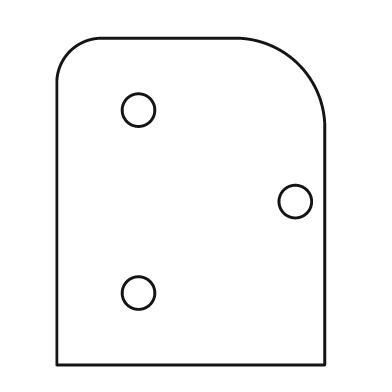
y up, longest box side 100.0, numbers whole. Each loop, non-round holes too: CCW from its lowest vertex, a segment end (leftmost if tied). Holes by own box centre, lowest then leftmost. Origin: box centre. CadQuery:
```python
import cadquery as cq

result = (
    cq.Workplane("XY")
    .moveTo(-41.0, -50.0)
    .lineTo(41.0, -50.0)
    .lineTo(41.0, 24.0)
    .threePointArc((33.0, 42.0), (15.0, 50.0))
    .lineTo(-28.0, 50.0)
    .threePointArc((-37.0, 46.0), (-41.0, 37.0))
    .close()
    .moveTo(-16.0, -28.0)
    .circle(5.0)
    .moveTo(32.0, 0.0)
    .circle(5.0)
    .moveTo(-16.0, 28.0)
    .circle(5.0)
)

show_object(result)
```